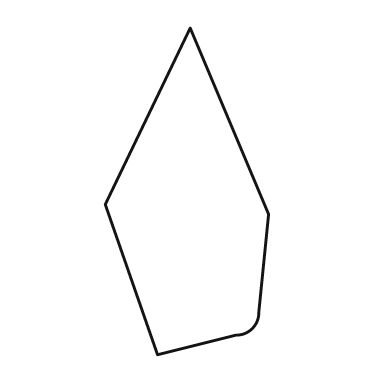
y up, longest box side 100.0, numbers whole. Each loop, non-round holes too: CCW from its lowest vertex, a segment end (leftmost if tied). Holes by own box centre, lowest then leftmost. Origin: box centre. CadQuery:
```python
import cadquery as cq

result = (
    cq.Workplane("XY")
    .moveTo(-9.0, -50.0)
    .lineTo(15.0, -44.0)
    .threePointArc((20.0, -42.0), (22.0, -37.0))
    .lineTo(25.0, -7.0)
    .lineTo(1.0, 50.0)
    .lineTo(-25.0, -4.0)
    .close()
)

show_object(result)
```